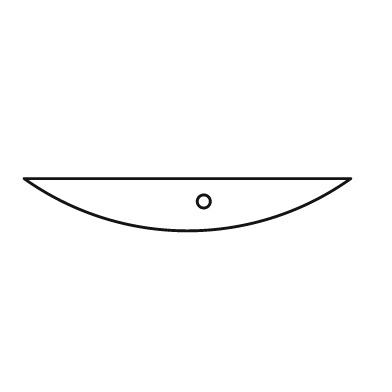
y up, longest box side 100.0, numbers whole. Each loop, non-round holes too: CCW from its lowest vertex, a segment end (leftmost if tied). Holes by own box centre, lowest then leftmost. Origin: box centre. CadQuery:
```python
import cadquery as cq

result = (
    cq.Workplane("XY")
    .moveTo(-50.0, 8.0)
    .threePointArc((0.0, -8.0), (50.0, 8.0))
    .close()
    .moveTo(5.0, 1.0)
    .circle(2.0)
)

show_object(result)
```